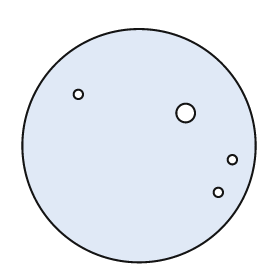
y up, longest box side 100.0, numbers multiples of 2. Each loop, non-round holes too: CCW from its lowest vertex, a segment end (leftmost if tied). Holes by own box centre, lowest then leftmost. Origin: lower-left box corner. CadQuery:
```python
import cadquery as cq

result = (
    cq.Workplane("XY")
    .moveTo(50.0, 50.0)
    .circle(50.0)
    .moveTo(84.0, 30.0)
    .circle(2.0)
    .moveTo(90.0, 44.0)
    .circle(2.0)
    .moveTo(70.0, 64.0)
    .circle(4.0)
    .moveTo(24.0, 72.0)
    .circle(2.0)
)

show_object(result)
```